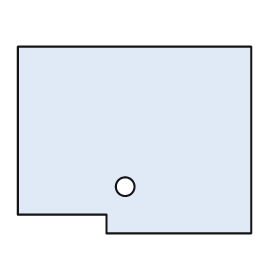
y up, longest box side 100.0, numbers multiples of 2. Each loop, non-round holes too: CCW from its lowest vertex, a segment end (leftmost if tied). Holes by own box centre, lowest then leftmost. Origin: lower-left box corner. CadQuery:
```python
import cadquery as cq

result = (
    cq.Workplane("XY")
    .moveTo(38.0, 0.0)
    .lineTo(100.0, 0.0)
    .lineTo(100.0, 80.0)
    .lineTo(0.0, 80.0)
    .lineTo(0.0, 8.0)
    .lineTo(38.0, 8.0)
    .close()
    .moveTo(46.0, 20.0)
    .circle(4.0)
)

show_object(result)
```